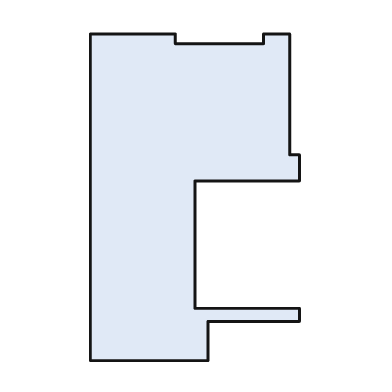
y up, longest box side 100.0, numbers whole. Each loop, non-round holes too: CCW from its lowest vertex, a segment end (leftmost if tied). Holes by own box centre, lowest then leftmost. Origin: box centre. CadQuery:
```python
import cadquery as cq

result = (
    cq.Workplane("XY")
    .moveTo(-32.0, -50.0)
    .lineTo(4.0, -50.0)
    .lineTo(4.0, -38.0)
    .lineTo(32.0, -38.0)
    .lineTo(32.0, -34.0)
    .lineTo(0.0, -34.0)
    .lineTo(0.0, 5.0)
    .lineTo(32.0, 5.0)
    .lineTo(32.0, 13.0)
    .lineTo(29.0, 13.0)
    .lineTo(29.0, 50.0)
    .lineTo(21.0, 50.0)
    .lineTo(21.0, 47.0)
    .lineTo(-6.0, 47.0)
    .lineTo(-6.0, 50.0)
    .lineTo(-32.0, 50.0)
    .close()
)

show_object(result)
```